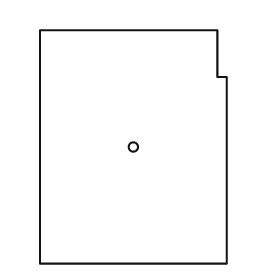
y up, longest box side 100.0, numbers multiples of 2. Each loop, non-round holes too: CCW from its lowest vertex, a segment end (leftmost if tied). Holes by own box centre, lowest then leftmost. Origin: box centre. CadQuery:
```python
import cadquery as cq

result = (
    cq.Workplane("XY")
    .moveTo(-40.0, -50.0)
    .lineTo(40.0, -50.0)
    .lineTo(40.0, 30.0)
    .lineTo(36.0, 30.0)
    .lineTo(36.0, 50.0)
    .lineTo(-40.0, 50.0)
    .close()
    .moveTo(0.0, 0.0)
    .circle(2.0)
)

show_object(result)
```